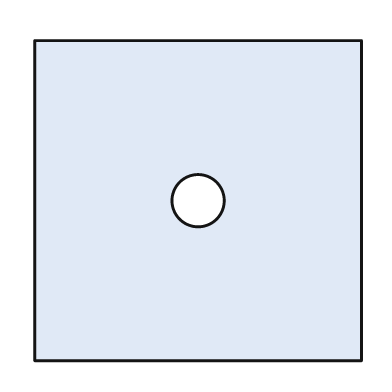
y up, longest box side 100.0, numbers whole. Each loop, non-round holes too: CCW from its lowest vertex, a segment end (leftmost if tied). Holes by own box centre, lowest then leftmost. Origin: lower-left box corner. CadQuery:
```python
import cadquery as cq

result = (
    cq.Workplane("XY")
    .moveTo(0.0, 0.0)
    .lineTo(100.0, 0.0)
    .lineTo(100.0, 98.0)
    .lineTo(0.0, 98.0)
    .close()
    .moveTo(50.0, 49.0)
    .circle(8.0)
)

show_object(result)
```